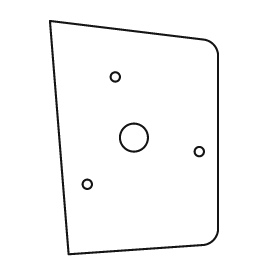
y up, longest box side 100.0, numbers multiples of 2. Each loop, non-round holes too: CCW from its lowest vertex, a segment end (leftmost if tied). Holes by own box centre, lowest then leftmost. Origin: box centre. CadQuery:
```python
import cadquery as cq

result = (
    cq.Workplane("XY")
    .moveTo(-28.0, -50.0)
    .lineTo(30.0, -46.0)
    .threePointArc((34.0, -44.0), (36.0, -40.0))
    .lineTo(36.0, 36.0)
    .threePointArc((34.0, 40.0), (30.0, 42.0))
    .lineTo(-36.0, 50.0)
    .close()
    .moveTo(-20.0, -20.0)
    .circle(2.0)
    .moveTo(28.0, -6.0)
    .circle(2.0)
    .moveTo(0.0, 0.0)
    .circle(6.0)
    .moveTo(-8.0, 26.0)
    .circle(2.0)
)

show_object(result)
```